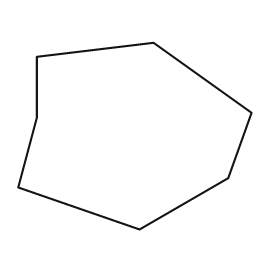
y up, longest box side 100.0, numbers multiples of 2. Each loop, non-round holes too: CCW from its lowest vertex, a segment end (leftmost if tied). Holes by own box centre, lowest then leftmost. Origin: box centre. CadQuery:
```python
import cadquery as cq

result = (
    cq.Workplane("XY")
    .moveTo(2.0, -40.0)
    .lineTo(40.0, -18.0)
    .lineTo(50.0, 10.0)
    .lineTo(8.0, 40.0)
    .lineTo(-42.0, 34.0)
    .lineTo(-42.0, 8.0)
    .lineTo(-50.0, -22.0)
    .close()
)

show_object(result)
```